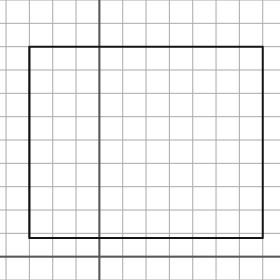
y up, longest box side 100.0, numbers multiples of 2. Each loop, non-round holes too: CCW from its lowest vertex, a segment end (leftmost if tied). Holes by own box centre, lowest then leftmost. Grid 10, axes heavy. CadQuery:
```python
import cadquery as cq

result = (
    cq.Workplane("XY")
    .moveTo(-30.0, 8.0)
    .lineTo(70.0, 8.0)
    .lineTo(70.0, 90.0)
    .lineTo(-30.0, 90.0)
    .close()
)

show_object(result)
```